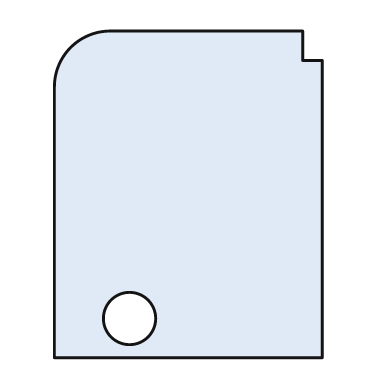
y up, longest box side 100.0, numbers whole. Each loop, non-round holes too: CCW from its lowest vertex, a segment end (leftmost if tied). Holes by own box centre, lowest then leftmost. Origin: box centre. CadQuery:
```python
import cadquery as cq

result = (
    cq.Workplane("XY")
    .moveTo(-41.0, -50.0)
    .lineTo(41.0, -50.0)
    .lineTo(41.0, 41.0)
    .lineTo(35.0, 41.0)
    .lineTo(35.0, 50.0)
    .lineTo(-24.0, 50.0)
    .threePointArc((-36.0, 45.0), (-41.0, 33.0))
    .close()
    .moveTo(-18.0, -38.0)
    .circle(8.0)
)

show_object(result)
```